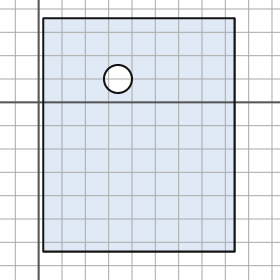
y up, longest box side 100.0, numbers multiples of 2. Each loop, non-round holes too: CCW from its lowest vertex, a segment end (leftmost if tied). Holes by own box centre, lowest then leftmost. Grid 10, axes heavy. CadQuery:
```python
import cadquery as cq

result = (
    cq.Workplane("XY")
    .moveTo(2.0, -64.0)
    .lineTo(84.0, -64.0)
    .lineTo(84.0, 36.0)
    .lineTo(2.0, 36.0)
    .close()
    .moveTo(34.0, 10.0)
    .circle(6.0)
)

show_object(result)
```